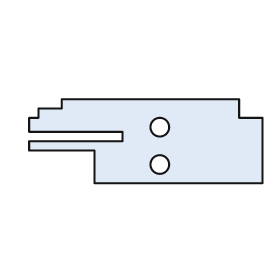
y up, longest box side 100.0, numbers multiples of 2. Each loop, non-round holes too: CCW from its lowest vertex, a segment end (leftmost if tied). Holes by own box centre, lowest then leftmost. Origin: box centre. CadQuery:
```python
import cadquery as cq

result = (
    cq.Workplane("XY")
    .moveTo(-22.0, -18.0)
    .lineTo(50.0, -18.0)
    .lineTo(50.0, 10.0)
    .lineTo(40.0, 10.0)
    .lineTo(40.0, 18.0)
    .lineTo(-36.0, 18.0)
    .lineTo(-36.0, 14.0)
    .lineTo(-46.0, 14.0)
    .lineTo(-46.0, 10.0)
    .lineTo(-50.0, 10.0)
    .lineTo(-50.0, 4.0)
    .lineTo(-10.0, 4.0)
    .lineTo(-10.0, 0.0)
    .lineTo(-50.0, 0.0)
    .lineTo(-50.0, -4.0)
    .lineTo(-22.0, -4.0)
    .close()
    .moveTo(6.0, -10.0)
    .circle(4.0)
    .moveTo(6.0, 6.0)
    .circle(4.0)
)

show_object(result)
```